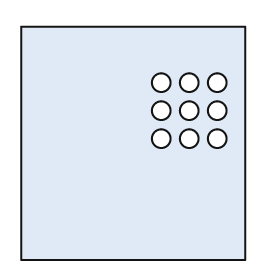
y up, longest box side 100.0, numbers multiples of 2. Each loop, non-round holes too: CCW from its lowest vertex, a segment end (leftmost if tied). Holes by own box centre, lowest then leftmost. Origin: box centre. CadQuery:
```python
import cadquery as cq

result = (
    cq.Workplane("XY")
    .moveTo(-48.0, -50.0)
    .lineTo(48.0, -50.0)
    .lineTo(48.0, 50.0)
    .lineTo(-48.0, 50.0)
    .close()
    .moveTo(12.0, 2.0)
    .circle(4.0)
    .moveTo(24.0, 2.0)
    .circle(4.0)
    .moveTo(36.0, 2.0)
    .circle(4.0)
    .moveTo(12.0, 14.0)
    .circle(4.0)
    .moveTo(24.0, 14.0)
    .circle(4.0)
    .moveTo(36.0, 14.0)
    .circle(4.0)
    .moveTo(12.0, 26.0)
    .circle(4.0)
    .moveTo(24.0, 26.0)
    .circle(4.0)
    .moveTo(36.0, 26.0)
    .circle(4.0)
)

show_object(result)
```